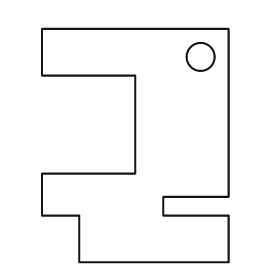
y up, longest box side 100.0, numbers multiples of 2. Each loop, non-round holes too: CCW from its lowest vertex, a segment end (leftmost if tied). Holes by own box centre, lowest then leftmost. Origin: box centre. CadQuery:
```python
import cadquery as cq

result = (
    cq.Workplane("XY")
    .moveTo(-24.0, -50.0)
    .lineTo(40.0, -50.0)
    .lineTo(40.0, -30.0)
    .lineTo(12.0, -30.0)
    .lineTo(12.0, -22.0)
    .lineTo(40.0, -22.0)
    .lineTo(40.0, 50.0)
    .lineTo(-40.0, 50.0)
    .lineTo(-40.0, 30.0)
    .lineTo(0.0, 30.0)
    .lineTo(0.0, -12.0)
    .lineTo(-40.0, -12.0)
    .lineTo(-40.0, -30.0)
    .lineTo(-24.0, -30.0)
    .close()
    .moveTo(28.0, 38.0)
    .circle(6.0)
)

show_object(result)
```